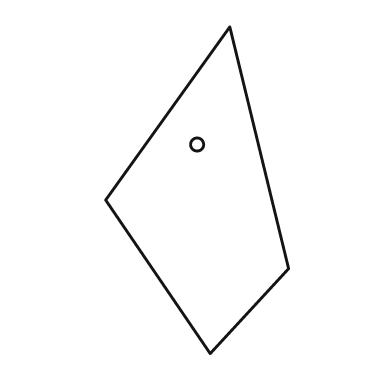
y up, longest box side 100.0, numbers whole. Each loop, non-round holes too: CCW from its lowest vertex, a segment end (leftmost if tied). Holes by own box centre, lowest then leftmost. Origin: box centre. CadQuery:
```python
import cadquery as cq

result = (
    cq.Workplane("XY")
    .moveTo(4.0, -50.0)
    .lineTo(28.0, -24.0)
    .lineTo(10.0, 50.0)
    .lineTo(-28.0, -3.0)
    .close()
    .moveTo(0.0, 14.0)
    .circle(2.0)
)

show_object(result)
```